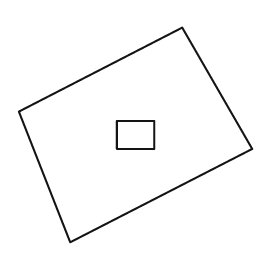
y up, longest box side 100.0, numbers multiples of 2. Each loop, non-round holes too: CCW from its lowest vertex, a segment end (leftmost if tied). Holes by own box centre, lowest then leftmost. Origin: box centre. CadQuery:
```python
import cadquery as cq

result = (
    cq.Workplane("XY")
    .moveTo(-28.0, -46.0)
    .lineTo(50.0, -6.0)
    .lineTo(20.0, 46.0)
    .lineTo(-50.0, 10.0)
    .close()
    .moveTo(-8.0, -6.0)
    .lineTo(8.0, -6.0)
    .lineTo(8.0, 6.0)
    .lineTo(-8.0, 6.0)
    .close()
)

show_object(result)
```